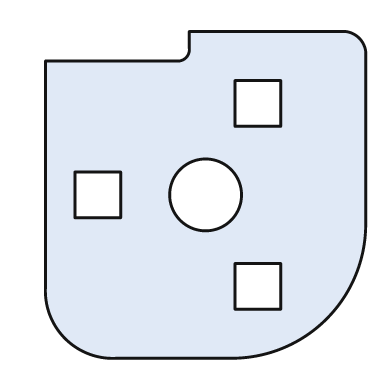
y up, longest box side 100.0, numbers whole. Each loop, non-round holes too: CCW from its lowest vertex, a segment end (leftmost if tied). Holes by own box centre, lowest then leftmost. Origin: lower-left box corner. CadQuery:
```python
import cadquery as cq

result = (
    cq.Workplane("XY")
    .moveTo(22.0, 0.0)
    .lineTo(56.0, 0.0)
    .threePointArc((86.0, 12.0), (98.0, 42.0))
    .lineTo(98.0, 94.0)
    .threePointArc((96.0, 98.0), (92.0, 100.0))
    .lineTo(44.0, 100.0)
    .lineTo(44.0, 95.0)
    .threePointArc((43.0, 92.0), (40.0, 91.0))
    .lineTo(0.0, 91.0)
    .lineTo(0.0, 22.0)
    .threePointArc((6.0, 6.0), (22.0, 0.0))
    .close()
    .moveTo(58.0, 15.0)
    .lineTo(72.0, 15.0)
    .lineTo(72.0, 29.0)
    .lineTo(58.0, 29.0)
    .close()
    .moveTo(9.0, 43.0)
    .lineTo(23.0, 43.0)
    .lineTo(23.0, 57.0)
    .lineTo(9.0, 57.0)
    .close()
    .moveTo(49.0, 50.0)
    .circle(11.0)
    .moveTo(58.0, 71.0)
    .lineTo(72.0, 71.0)
    .lineTo(72.0, 85.0)
    .lineTo(58.0, 85.0)
    .close()
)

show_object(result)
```